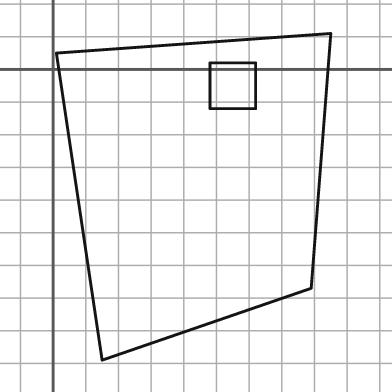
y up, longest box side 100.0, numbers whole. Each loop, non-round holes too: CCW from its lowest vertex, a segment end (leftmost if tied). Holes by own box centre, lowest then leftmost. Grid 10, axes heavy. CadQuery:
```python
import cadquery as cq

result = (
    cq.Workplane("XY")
    .moveTo(15.0, -89.0)
    .lineTo(79.0, -67.0)
    .lineTo(85.0, 11.0)
    .lineTo(1.0, 5.0)
    .close()
    .moveTo(48.0, -12.0)
    .lineTo(62.0, -12.0)
    .lineTo(62.0, 2.0)
    .lineTo(48.0, 2.0)
    .close()
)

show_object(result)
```